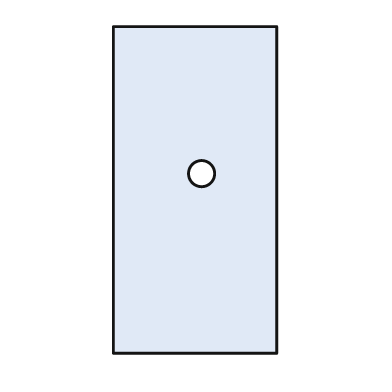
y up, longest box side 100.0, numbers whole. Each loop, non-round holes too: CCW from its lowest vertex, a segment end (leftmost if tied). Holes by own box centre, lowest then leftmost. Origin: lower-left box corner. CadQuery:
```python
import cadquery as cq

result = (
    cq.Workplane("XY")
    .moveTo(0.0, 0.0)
    .lineTo(50.0, 0.0)
    .lineTo(50.0, 100.0)
    .lineTo(0.0, 100.0)
    .close()
    .moveTo(27.0, 55.0)
    .circle(4.0)
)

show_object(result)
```